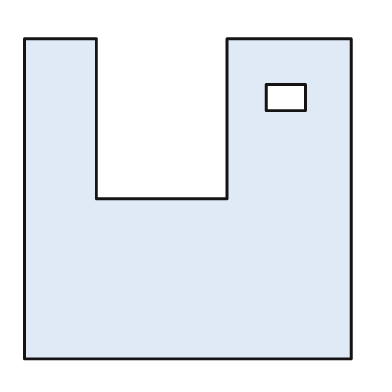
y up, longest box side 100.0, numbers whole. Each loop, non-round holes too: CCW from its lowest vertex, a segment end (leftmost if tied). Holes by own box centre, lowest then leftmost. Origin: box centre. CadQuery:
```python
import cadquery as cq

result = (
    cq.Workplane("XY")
    .moveTo(-50.0, -49.0)
    .lineTo(50.0, -49.0)
    .lineTo(50.0, 49.0)
    .lineTo(12.0, 49.0)
    .lineTo(12.0, 0.0)
    .lineTo(-28.0, 0.0)
    .lineTo(-28.0, 49.0)
    .lineTo(-50.0, 49.0)
    .close()
    .moveTo(24.0, 27.0)
    .lineTo(36.0, 27.0)
    .lineTo(36.0, 35.0)
    .lineTo(24.0, 35.0)
    .close()
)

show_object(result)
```